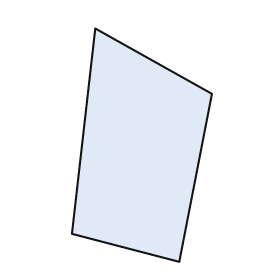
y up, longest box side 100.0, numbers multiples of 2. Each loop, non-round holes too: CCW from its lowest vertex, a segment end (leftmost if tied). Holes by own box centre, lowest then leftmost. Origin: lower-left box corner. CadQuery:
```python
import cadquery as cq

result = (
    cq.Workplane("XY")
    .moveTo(46.0, 0.0)
    .lineTo(60.0, 72.0)
    .lineTo(10.0, 100.0)
    .lineTo(0.0, 12.0)
    .close()
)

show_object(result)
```